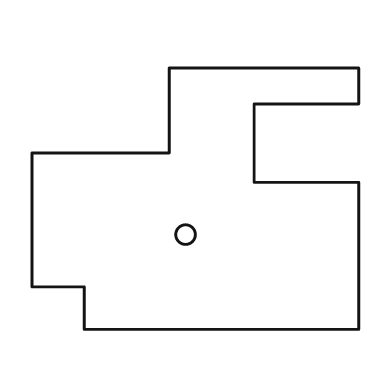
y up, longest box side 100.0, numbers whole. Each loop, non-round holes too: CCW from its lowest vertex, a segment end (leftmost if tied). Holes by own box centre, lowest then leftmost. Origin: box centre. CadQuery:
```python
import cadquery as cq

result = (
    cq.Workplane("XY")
    .moveTo(-34.0, -40.0)
    .lineTo(50.0, -40.0)
    .lineTo(50.0, 5.0)
    .lineTo(18.0, 5.0)
    .lineTo(18.0, 29.0)
    .lineTo(50.0, 29.0)
    .lineTo(50.0, 40.0)
    .lineTo(-8.0, 40.0)
    .lineTo(-8.0, 14.0)
    .lineTo(-50.0, 14.0)
    .lineTo(-50.0, -27.0)
    .lineTo(-34.0, -27.0)
    .close()
    .moveTo(-3.0, -11.0)
    .circle(3.0)
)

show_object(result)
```